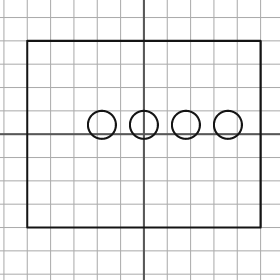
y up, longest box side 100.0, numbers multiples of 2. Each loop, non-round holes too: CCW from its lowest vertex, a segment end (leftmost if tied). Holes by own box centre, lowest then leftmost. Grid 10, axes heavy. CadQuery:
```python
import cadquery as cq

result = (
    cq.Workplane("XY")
    .moveTo(-50.0, -40.0)
    .lineTo(50.0, -40.0)
    .lineTo(50.0, 40.0)
    .lineTo(-50.0, 40.0)
    .close()
    .moveTo(-18.0, 4.0)
    .circle(6.0)
    .moveTo(0.0, 4.0)
    .circle(6.0)
    .moveTo(18.0, 4.0)
    .circle(6.0)
    .moveTo(36.0, 4.0)
    .circle(6.0)
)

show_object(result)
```